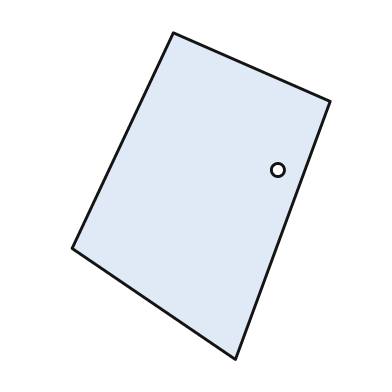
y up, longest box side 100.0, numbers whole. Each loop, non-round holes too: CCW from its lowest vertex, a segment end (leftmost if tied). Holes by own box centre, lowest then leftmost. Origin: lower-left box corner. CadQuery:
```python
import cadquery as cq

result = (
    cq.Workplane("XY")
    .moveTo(50.0, 0.0)
    .lineTo(79.0, 79.0)
    .lineTo(31.0, 100.0)
    .lineTo(0.0, 34.0)
    .close()
    .moveTo(63.0, 58.0)
    .circle(2.0)
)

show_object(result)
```